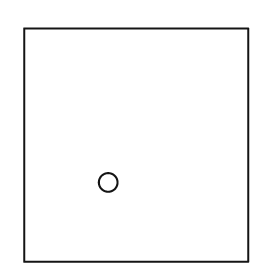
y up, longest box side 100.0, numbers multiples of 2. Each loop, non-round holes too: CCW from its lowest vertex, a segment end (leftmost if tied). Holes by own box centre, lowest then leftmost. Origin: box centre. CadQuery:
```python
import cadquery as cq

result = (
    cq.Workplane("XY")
    .moveTo(-48.0, -50.0)
    .lineTo(48.0, -50.0)
    .lineTo(48.0, 50.0)
    .lineTo(-48.0, 50.0)
    .close()
    .moveTo(-12.0, -16.0)
    .circle(4.0)
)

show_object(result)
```